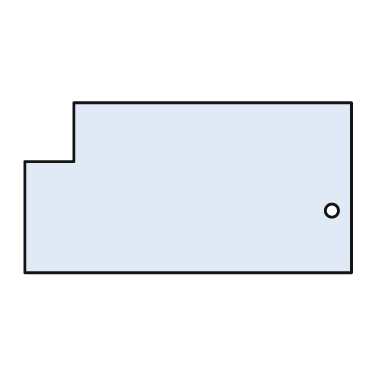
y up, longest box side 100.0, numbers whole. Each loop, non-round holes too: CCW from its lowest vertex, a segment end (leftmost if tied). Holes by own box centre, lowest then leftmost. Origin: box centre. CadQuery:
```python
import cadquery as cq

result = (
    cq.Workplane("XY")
    .moveTo(-50.0, -26.0)
    .lineTo(50.0, -26.0)
    .lineTo(50.0, 26.0)
    .lineTo(-35.0, 26.0)
    .lineTo(-35.0, 8.0)
    .lineTo(-50.0, 8.0)
    .close()
    .moveTo(44.0, -7.0)
    .circle(2.0)
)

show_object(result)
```